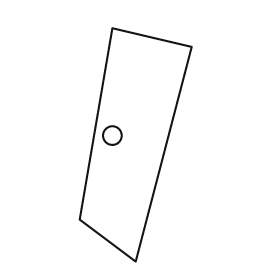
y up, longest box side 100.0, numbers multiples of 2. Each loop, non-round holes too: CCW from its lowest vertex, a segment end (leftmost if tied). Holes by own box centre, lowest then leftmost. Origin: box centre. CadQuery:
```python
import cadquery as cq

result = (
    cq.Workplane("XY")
    .moveTo(0.0, -50.0)
    .lineTo(24.0, 42.0)
    .lineTo(-10.0, 50.0)
    .lineTo(-24.0, -32.0)
    .close()
    .moveTo(-10.0, 4.0)
    .circle(4.0)
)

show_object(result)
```